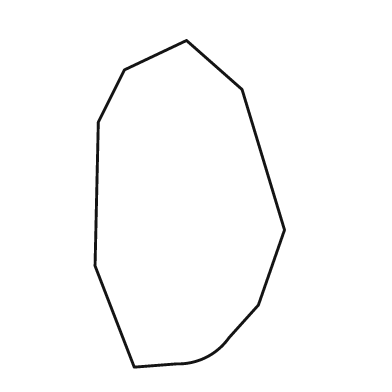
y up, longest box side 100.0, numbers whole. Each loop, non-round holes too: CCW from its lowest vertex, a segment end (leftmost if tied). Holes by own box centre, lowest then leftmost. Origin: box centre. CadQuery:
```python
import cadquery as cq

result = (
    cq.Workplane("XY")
    .moveTo(-17.0, -50.0)
    .lineTo(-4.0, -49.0)
    .threePointArc((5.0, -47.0), (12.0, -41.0))
    .lineTo(21.0, -31.0)
    .lineTo(29.0, -8.0)
    .lineTo(16.0, 35.0)
    .lineTo(-1.0, 50.0)
    .lineTo(-20.0, 41.0)
    .lineTo(-28.0, 25.0)
    .lineTo(-29.0, -19.0)
    .close()
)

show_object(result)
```